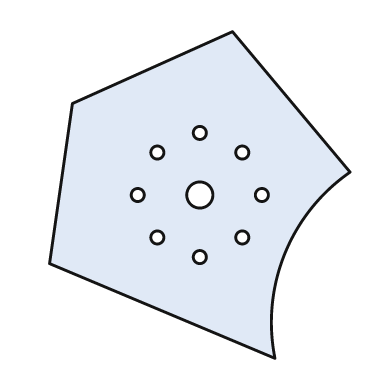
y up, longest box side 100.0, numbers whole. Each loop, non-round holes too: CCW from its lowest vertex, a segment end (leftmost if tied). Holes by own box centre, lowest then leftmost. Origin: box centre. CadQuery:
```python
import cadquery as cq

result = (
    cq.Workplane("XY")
    .moveTo(23.0, -50.0)
    .threePointArc((26.0, -18.0), (46.0, 7.0))
    .lineTo(10.0, 50.0)
    .lineTo(-39.0, 28.0)
    .lineTo(-46.0, -21.0)
    .close()
    .moveTo(0.0, -19.0)
    .circle(2.0)
    .moveTo(-13.0, -13.0)
    .circle(2.0)
    .moveTo(13.0, -13.0)
    .circle(2.0)
    .moveTo(-19.0, 0.0)
    .circle(2.0)
    .moveTo(0.0, 0.0)
    .circle(4.0)
    .moveTo(19.0, 0.0)
    .circle(2.0)
    .moveTo(-13.0, 13.0)
    .circle(2.0)
    .moveTo(13.0, 13.0)
    .circle(2.0)
    .moveTo(0.0, 19.0)
    .circle(2.0)
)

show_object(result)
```